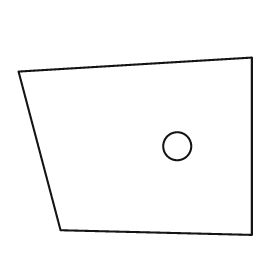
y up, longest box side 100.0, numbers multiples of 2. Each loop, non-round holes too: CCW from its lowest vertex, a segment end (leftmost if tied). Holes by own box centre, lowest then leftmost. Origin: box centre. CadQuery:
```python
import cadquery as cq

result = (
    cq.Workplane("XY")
    .moveTo(50.0, -38.0)
    .lineTo(50.0, 38.0)
    .lineTo(-50.0, 32.0)
    .lineTo(-32.0, -36.0)
    .close()
    .moveTo(18.0, 0.0)
    .circle(6.0)
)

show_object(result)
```